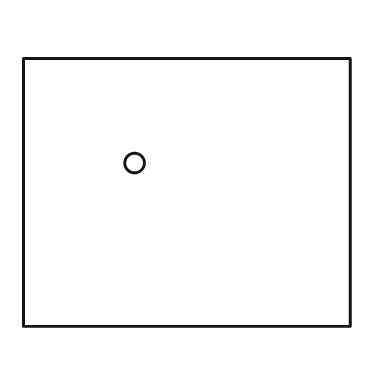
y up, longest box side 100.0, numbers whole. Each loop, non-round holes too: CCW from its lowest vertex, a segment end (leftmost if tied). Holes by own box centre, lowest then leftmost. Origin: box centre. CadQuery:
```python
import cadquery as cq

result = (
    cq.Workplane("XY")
    .moveTo(-50.0, -41.0)
    .lineTo(50.0, -41.0)
    .lineTo(50.0, 41.0)
    .lineTo(-50.0, 41.0)
    .close()
    .moveTo(-16.0, 9.0)
    .circle(3.0)
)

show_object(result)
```